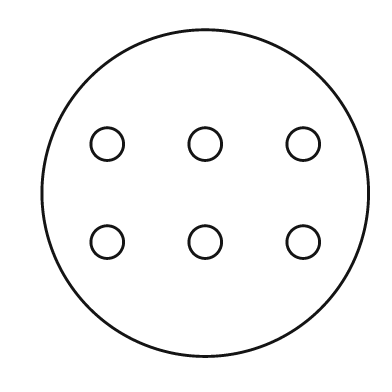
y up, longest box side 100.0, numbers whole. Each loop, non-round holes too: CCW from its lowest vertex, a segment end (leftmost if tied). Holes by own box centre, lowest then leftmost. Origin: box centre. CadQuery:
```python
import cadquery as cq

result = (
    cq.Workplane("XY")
    .moveTo(0.0, 0.0)
    .circle(50.0)
    .moveTo(-30.0, -15.0)
    .circle(5.0)
    .moveTo(0.0, -15.0)
    .circle(5.0)
    .moveTo(30.0, -15.0)
    .circle(5.0)
    .moveTo(-30.0, 15.0)
    .circle(5.0)
    .moveTo(0.0, 15.0)
    .circle(5.0)
    .moveTo(30.0, 15.0)
    .circle(5.0)
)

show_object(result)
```